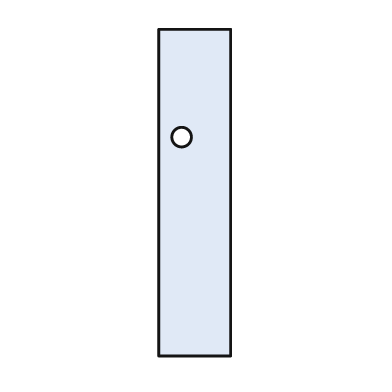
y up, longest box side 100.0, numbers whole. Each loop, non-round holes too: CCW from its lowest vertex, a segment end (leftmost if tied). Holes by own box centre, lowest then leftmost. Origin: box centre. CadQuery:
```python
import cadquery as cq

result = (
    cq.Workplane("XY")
    .moveTo(-11.0, -50.0)
    .lineTo(11.0, -50.0)
    .lineTo(11.0, 50.0)
    .lineTo(-11.0, 50.0)
    .close()
    .moveTo(-4.0, 17.0)
    .circle(3.0)
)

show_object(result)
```